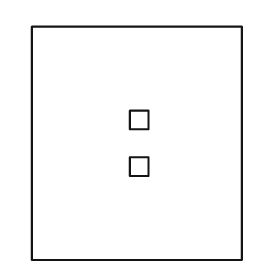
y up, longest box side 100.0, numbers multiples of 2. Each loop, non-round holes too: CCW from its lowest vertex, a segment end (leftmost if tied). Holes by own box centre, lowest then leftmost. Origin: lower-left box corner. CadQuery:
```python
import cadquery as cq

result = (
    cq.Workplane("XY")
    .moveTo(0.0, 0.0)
    .lineTo(90.0, 0.0)
    .lineTo(90.0, 100.0)
    .lineTo(0.0, 100.0)
    .close()
    .moveTo(42.0, 36.0)
    .lineTo(50.0, 36.0)
    .lineTo(50.0, 44.0)
    .lineTo(42.0, 44.0)
    .close()
    .moveTo(42.0, 56.0)
    .lineTo(50.0, 56.0)
    .lineTo(50.0, 64.0)
    .lineTo(42.0, 64.0)
    .close()
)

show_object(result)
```